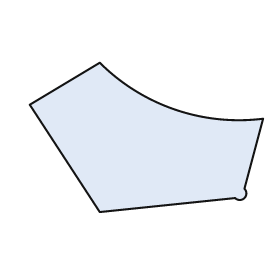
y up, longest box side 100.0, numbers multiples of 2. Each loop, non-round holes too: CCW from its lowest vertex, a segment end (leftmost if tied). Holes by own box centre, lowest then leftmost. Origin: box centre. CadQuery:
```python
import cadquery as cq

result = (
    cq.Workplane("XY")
    .moveTo(-20.0, -32.0)
    .lineTo(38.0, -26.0)
    .threePointArc((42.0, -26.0), (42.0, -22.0))
    .lineTo(50.0, 8.0)
    .threePointArc((12.0, 12.0), (-20.0, 32.0))
    .lineTo(-50.0, 14.0)
    .close()
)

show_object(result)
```